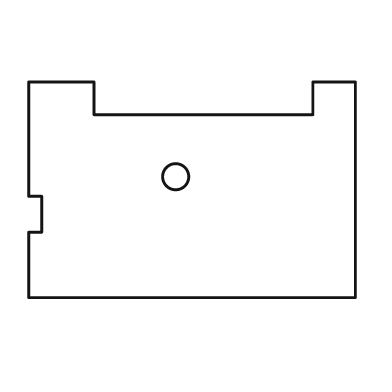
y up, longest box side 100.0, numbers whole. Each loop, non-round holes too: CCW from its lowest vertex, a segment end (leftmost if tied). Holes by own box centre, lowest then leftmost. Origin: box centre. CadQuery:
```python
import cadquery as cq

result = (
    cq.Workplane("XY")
    .moveTo(-50.0, -33.0)
    .lineTo(50.0, -33.0)
    .lineTo(50.0, 33.0)
    .lineTo(37.0, 33.0)
    .lineTo(37.0, 23.0)
    .lineTo(-30.0, 23.0)
    .lineTo(-30.0, 33.0)
    .lineTo(-50.0, 33.0)
    .lineTo(-50.0, -2.0)
    .lineTo(-46.0, -2.0)
    .lineTo(-46.0, -13.0)
    .lineTo(-50.0, -13.0)
    .close()
    .moveTo(-5.0, 4.0)
    .circle(4.0)
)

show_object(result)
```